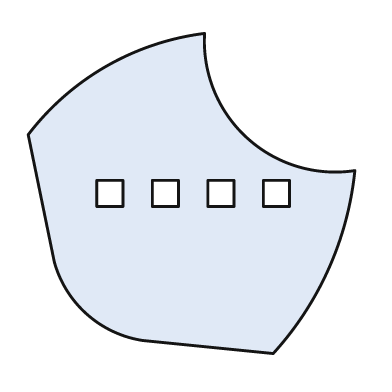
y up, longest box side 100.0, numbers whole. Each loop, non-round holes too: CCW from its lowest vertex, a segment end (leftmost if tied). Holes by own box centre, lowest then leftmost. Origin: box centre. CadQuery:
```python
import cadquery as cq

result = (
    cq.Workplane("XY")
    .moveTo(25.0, -49.0)
    .threePointArc((42.0, -23.0), (50.0, 7.0))
    .threePointArc((17.0, 17.0), (4.0, 49.0))
    .threePointArc((-26.0, 39.0), (-50.0, 18.0))
    .lineTo(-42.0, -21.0)
    .threePointArc((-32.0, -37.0), (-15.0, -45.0))
    .close()
    .moveTo(-29.0, -4.0)
    .lineTo(-21.0, -4.0)
    .lineTo(-21.0, 4.0)
    .lineTo(-29.0, 4.0)
    .close()
    .moveTo(-12.0, -4.0)
    .lineTo(-4.0, -4.0)
    .lineTo(-4.0, 4.0)
    .lineTo(-12.0, 4.0)
    .close()
    .moveTo(5.0, -4.0)
    .lineTo(13.0, -4.0)
    .lineTo(13.0, 4.0)
    .lineTo(5.0, 4.0)
    .close()
    .moveTo(22.0, -4.0)
    .lineTo(30.0, -4.0)
    .lineTo(30.0, 4.0)
    .lineTo(22.0, 4.0)
    .close()
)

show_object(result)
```